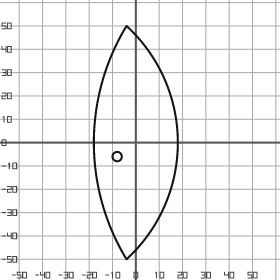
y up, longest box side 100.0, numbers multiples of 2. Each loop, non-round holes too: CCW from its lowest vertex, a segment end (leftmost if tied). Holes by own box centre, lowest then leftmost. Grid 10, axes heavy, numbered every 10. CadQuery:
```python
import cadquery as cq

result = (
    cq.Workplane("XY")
    .moveTo(-4.0, -50.0)
    .threePointArc((18.0, 0.0), (-4.0, 50.0))
    .threePointArc((-18.0, 0.0), (-4.0, -50.0))
    .close()
    .moveTo(-8.0, -6.0)
    .circle(2.0)
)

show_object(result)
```